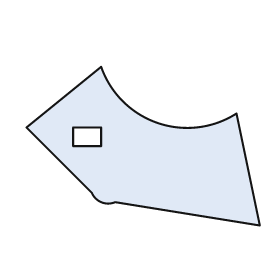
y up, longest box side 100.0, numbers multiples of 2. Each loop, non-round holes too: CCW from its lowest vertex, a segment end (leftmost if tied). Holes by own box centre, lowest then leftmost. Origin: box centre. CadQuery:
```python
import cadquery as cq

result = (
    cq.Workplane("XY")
    .moveTo(50.0, -34.0)
    .lineTo(40.0, 14.0)
    .threePointArc((6.0, 10.0), (-18.0, 34.0))
    .lineTo(-50.0, 8.0)
    .lineTo(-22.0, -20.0)
    .threePointArc((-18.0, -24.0), (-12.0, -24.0))
    .close()
    .moveTo(-30.0, 0.0)
    .lineTo(-18.0, 0.0)
    .lineTo(-18.0, 8.0)
    .lineTo(-30.0, 8.0)
    .close()
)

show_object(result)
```